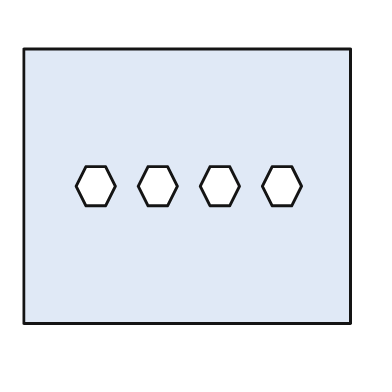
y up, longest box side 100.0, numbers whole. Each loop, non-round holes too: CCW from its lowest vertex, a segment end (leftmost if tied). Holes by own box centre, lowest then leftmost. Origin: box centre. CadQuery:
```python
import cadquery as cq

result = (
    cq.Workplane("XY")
    .moveTo(-50.0, -42.0)
    .lineTo(50.0, -42.0)
    .lineTo(50.0, 42.0)
    .lineTo(-50.0, 42.0)
    .close()
    .moveTo(-31.0, -6.0)
    .lineTo(-25.0, -6.0)
    .lineTo(-22.0, 0.0)
    .lineTo(-25.0, 6.0)
    .lineTo(-31.0, 6.0)
    .lineTo(-34.0, 0.0)
    .close()
    .moveTo(-12.0, -6.0)
    .lineTo(-6.0, -6.0)
    .lineTo(-3.0, 0.0)
    .lineTo(-6.0, 6.0)
    .lineTo(-12.0, 6.0)
    .lineTo(-15.0, 0.0)
    .close()
    .moveTo(7.0, -6.0)
    .lineTo(13.0, -6.0)
    .lineTo(16.0, 0.0)
    .lineTo(13.0, 6.0)
    .lineTo(7.0, 6.0)
    .lineTo(4.0, 0.0)
    .close()
    .moveTo(26.0, -6.0)
    .lineTo(32.0, -6.0)
    .lineTo(35.0, 0.0)
    .lineTo(32.0, 6.0)
    .lineTo(26.0, 6.0)
    .lineTo(23.0, 0.0)
    .close()
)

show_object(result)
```